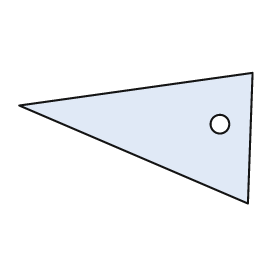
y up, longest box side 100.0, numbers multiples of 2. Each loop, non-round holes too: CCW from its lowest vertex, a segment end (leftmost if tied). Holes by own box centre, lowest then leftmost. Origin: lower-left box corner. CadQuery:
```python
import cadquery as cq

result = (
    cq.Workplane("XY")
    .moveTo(98.0, 0.0)
    .lineTo(100.0, 56.0)
    .lineTo(0.0, 42.0)
    .close()
    .moveTo(86.0, 34.0)
    .circle(4.0)
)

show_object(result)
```